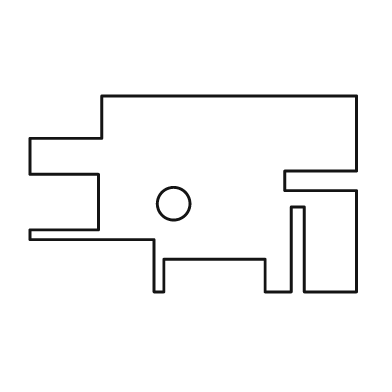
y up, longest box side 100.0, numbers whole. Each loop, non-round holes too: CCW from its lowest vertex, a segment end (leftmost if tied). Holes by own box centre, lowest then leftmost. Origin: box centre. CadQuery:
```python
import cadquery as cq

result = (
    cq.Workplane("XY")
    .moveTo(-12.0, -30.0)
    .lineTo(-9.0, -30.0)
    .lineTo(-9.0, -20.0)
    .lineTo(22.0, -20.0)
    .lineTo(22.0, -30.0)
    .lineTo(30.0, -30.0)
    .lineTo(30.0, -4.0)
    .lineTo(34.0, -4.0)
    .lineTo(34.0, -30.0)
    .lineTo(50.0, -30.0)
    .lineTo(50.0, 1.0)
    .lineTo(28.0, 1.0)
    .lineTo(28.0, 7.0)
    .lineTo(50.0, 7.0)
    .lineTo(50.0, 30.0)
    .lineTo(-28.0, 30.0)
    .lineTo(-28.0, 17.0)
    .lineTo(-50.0, 17.0)
    .lineTo(-50.0, 6.0)
    .lineTo(-29.0, 6.0)
    .lineTo(-29.0, -11.0)
    .lineTo(-50.0, -11.0)
    .lineTo(-50.0, -14.0)
    .lineTo(-12.0, -14.0)
    .close()
    .moveTo(-6.0, -3.0)
    .circle(5.0)
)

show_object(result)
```